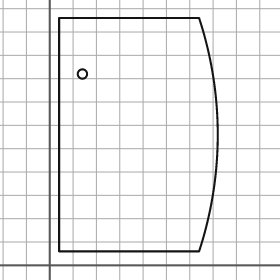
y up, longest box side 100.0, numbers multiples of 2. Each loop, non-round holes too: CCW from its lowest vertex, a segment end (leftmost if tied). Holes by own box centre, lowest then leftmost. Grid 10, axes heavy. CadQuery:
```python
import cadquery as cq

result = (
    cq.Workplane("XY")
    .moveTo(4.0, 6.0)
    .lineTo(64.0, 6.0)
    .threePointArc((72.0, 56.0), (64.0, 106.0))
    .lineTo(4.0, 106.0)
    .close()
    .moveTo(14.0, 82.0)
    .circle(2.0)
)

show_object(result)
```